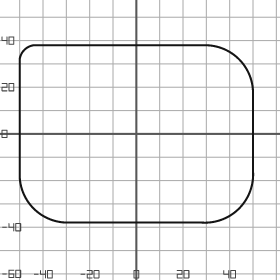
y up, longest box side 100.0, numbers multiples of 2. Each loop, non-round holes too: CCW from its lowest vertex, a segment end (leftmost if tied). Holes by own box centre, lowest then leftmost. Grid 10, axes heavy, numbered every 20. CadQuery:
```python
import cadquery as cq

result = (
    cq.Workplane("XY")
    .moveTo(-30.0, -38.0)
    .lineTo(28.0, -38.0)
    .threePointArc((44.0, -32.0), (50.0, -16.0))
    .lineTo(50.0, 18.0)
    .threePointArc((44.0, 32.0), (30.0, 38.0))
    .lineTo(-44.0, 38.0)
    .threePointArc((-48.0, 36.0), (-50.0, 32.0))
    .lineTo(-50.0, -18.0)
    .threePointArc((-44.0, -32.0), (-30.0, -38.0))
    .close()
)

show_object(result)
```